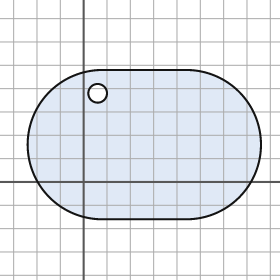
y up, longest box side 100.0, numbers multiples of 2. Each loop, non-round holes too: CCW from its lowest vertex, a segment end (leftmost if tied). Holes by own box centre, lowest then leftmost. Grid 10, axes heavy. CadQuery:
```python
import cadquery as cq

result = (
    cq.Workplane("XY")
    .moveTo(8.0, -16.0)
    .lineTo(44.0, -16.0)
    .threePointArc((76.0, 16.0), (44.0, 48.0))
    .lineTo(8.0, 48.0)
    .threePointArc((-24.0, 16.0), (8.0, -16.0))
    .close()
    .moveTo(6.0, 38.0)
    .circle(4.0)
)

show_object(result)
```